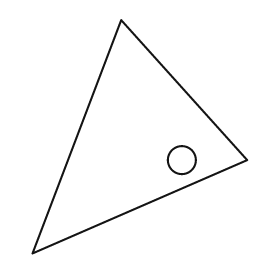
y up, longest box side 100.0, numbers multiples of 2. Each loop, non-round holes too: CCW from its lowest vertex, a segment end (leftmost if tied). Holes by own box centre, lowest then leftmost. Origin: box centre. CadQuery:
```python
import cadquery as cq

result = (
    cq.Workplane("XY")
    .moveTo(-46.0, -50.0)
    .lineTo(46.0, -10.0)
    .lineTo(-8.0, 50.0)
    .close()
    .moveTo(18.0, -10.0)
    .circle(6.0)
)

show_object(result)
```